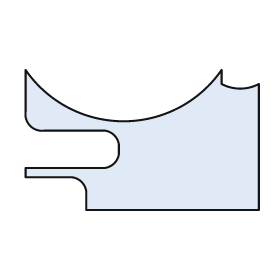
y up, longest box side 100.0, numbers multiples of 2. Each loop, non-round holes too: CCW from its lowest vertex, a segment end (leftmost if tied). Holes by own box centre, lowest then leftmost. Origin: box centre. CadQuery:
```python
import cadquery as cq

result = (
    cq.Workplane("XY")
    .moveTo(-24.0, -30.0)
    .lineTo(50.0, -30.0)
    .lineTo(50.0, 24.0)
    .threePointArc((42.0, 22.0), (34.0, 24.0))
    .lineTo(34.0, 30.0)
    .threePointArc((-8.0, 8.0), (-50.0, 30.0))
    .lineTo(-50.0, 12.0)
    .threePointArc((-48.0, 6.0), (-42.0, 4.0))
    .lineTo(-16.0, 4.0)
    .threePointArc((-12.0, 2.0), (-10.0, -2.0))
    .lineTo(-10.0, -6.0)
    .threePointArc((-12.0, -10.0), (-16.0, -12.0))
    .lineTo(-50.0, -12.0)
    .lineTo(-50.0, -16.0)
    .lineTo(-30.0, -16.0)
    .threePointArc((-26.0, -18.0), (-24.0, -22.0))
    .close()
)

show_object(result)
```